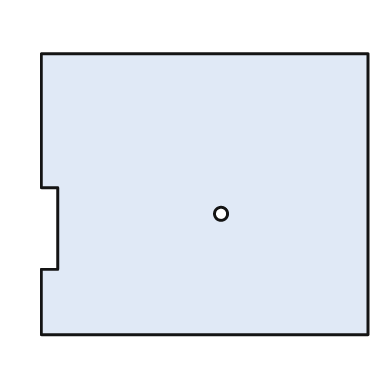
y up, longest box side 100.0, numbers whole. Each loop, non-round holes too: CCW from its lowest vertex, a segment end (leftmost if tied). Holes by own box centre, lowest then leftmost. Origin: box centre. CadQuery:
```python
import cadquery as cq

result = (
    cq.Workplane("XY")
    .moveTo(-50.0, -43.0)
    .lineTo(50.0, -43.0)
    .lineTo(50.0, 43.0)
    .lineTo(-50.0, 43.0)
    .lineTo(-50.0, 2.0)
    .lineTo(-45.0, 2.0)
    .lineTo(-45.0, -23.0)
    .lineTo(-50.0, -23.0)
    .close()
    .moveTo(5.0, -6.0)
    .circle(2.0)
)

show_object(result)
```